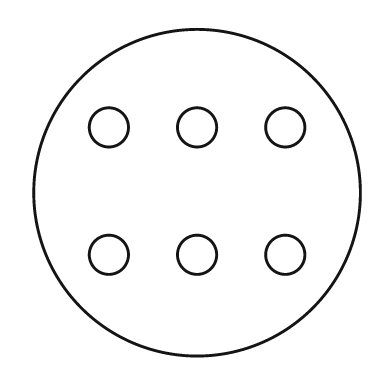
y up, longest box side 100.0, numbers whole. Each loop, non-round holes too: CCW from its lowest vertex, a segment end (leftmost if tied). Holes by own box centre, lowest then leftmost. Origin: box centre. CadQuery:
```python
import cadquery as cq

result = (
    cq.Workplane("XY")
    .moveTo(0.0, 0.0)
    .circle(50.0)
    .moveTo(-27.0, -19.0)
    .circle(6.0)
    .moveTo(0.0, -19.0)
    .circle(6.0)
    .moveTo(27.0, -19.0)
    .circle(6.0)
    .moveTo(-27.0, 20.0)
    .circle(6.0)
    .moveTo(0.0, 20.0)
    .circle(6.0)
    .moveTo(27.0, 20.0)
    .circle(6.0)
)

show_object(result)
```